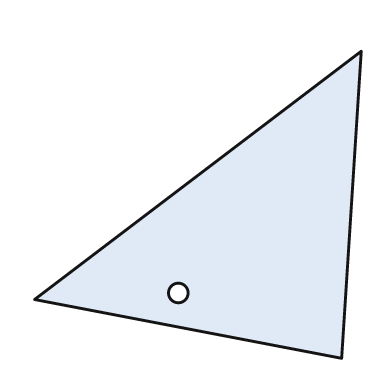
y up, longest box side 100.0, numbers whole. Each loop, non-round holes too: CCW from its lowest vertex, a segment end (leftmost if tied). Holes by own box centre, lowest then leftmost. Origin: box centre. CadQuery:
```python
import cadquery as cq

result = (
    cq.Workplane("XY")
    .moveTo(44.0, -47.0)
    .lineTo(50.0, 47.0)
    .lineTo(-50.0, -29.0)
    .close()
    .moveTo(-6.0, -27.0)
    .circle(3.0)
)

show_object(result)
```